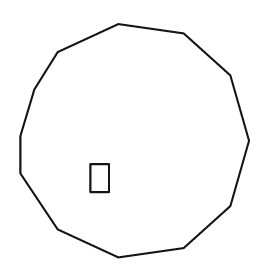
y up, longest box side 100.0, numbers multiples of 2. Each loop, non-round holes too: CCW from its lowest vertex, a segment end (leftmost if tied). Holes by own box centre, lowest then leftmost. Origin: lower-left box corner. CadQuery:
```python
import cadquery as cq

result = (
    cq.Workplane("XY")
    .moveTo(42.0, 0.0)
    .lineTo(70.0, 4.0)
    .lineTo(90.0, 22.0)
    .lineTo(98.0, 50.0)
    .lineTo(90.0, 78.0)
    .lineTo(70.0, 96.0)
    .lineTo(42.0, 100.0)
    .lineTo(16.0, 88.0)
    .lineTo(6.0, 72.0)
    .lineTo(0.0, 52.0)
    .lineTo(0.0, 36.0)
    .lineTo(16.0, 12.0)
    .close()
    .moveTo(30.0, 28.0)
    .lineTo(38.0, 28.0)
    .lineTo(38.0, 40.0)
    .lineTo(30.0, 40.0)
    .close()
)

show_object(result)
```